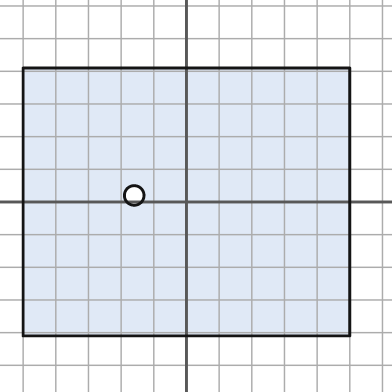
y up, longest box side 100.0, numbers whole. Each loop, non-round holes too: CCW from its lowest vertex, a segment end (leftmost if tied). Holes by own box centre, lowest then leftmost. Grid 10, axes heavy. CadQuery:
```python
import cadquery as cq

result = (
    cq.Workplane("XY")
    .moveTo(-50.0, -41.0)
    .lineTo(50.0, -41.0)
    .lineTo(50.0, 41.0)
    .lineTo(-50.0, 41.0)
    .close()
    .moveTo(-16.0, 2.0)
    .circle(3.0)
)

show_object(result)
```